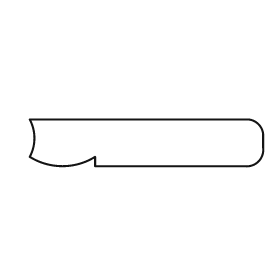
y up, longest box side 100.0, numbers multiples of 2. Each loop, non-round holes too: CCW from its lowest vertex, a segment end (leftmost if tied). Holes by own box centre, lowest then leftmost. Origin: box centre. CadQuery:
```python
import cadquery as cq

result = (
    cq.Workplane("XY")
    .moveTo(-22.0, -10.0)
    .lineTo(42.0, -10.0)
    .threePointArc((48.0, -8.0), (50.0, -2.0))
    .lineTo(50.0, 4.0)
    .threePointArc((48.0, 8.0), (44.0, 10.0))
    .lineTo(-50.0, 10.0)
    .threePointArc((-48.0, 2.0), (-50.0, -6.0))
    .threePointArc((-36.0, -10.0), (-22.0, -6.0))
    .close()
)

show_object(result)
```